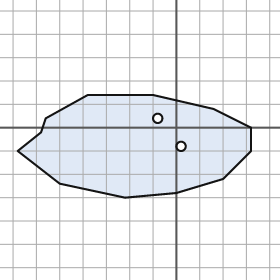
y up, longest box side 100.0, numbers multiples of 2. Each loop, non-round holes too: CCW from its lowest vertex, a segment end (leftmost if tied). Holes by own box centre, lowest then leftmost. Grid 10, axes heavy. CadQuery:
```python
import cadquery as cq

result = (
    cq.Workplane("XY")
    .moveTo(-22.0, -30.0)
    .lineTo(0.0, -28.0)
    .lineTo(20.0, -22.0)
    .lineTo(32.0, -10.0)
    .lineTo(32.0, 0.0)
    .lineTo(16.0, 8.0)
    .lineTo(-10.0, 14.0)
    .lineTo(-38.0, 14.0)
    .lineTo(-56.0, 4.0)
    .lineTo(-58.0, -2.0)
    .lineTo(-68.0, -10.0)
    .lineTo(-50.0, -24.0)
    .close()
    .moveTo(2.0, -8.0)
    .circle(2.0)
    .moveTo(-8.0, 4.0)
    .circle(2.0)
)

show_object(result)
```